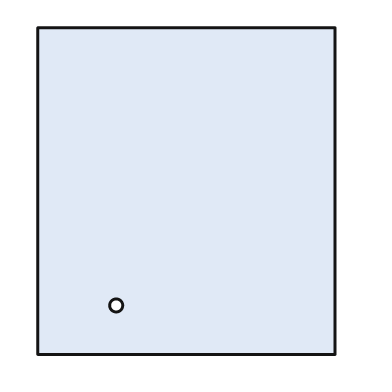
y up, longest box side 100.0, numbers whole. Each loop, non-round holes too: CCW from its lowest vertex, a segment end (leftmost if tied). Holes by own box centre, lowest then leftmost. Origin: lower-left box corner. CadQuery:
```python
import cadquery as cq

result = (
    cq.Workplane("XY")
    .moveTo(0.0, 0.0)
    .lineTo(91.0, 0.0)
    .lineTo(91.0, 100.0)
    .lineTo(0.0, 100.0)
    .close()
    .moveTo(24.0, 15.0)
    .circle(2.0)
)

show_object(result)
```